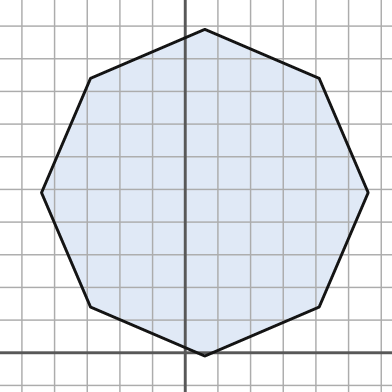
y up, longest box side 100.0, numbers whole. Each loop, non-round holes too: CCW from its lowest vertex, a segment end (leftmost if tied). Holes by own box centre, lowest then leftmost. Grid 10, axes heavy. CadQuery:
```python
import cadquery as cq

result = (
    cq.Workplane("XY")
    .moveTo(6.0, -1.0)
    .lineTo(41.0, 14.0)
    .lineTo(56.0, 49.0)
    .lineTo(41.0, 84.0)
    .lineTo(6.0, 99.0)
    .lineTo(-29.0, 84.0)
    .lineTo(-44.0, 49.0)
    .lineTo(-29.0, 14.0)
    .close()
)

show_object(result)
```